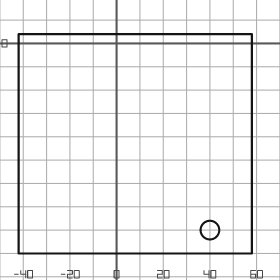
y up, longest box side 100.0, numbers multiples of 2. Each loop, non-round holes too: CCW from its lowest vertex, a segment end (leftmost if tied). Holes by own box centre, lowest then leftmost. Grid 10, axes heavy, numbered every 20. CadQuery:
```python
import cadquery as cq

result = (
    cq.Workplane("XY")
    .moveTo(-42.0, -90.0)
    .lineTo(58.0, -90.0)
    .lineTo(58.0, 4.0)
    .lineTo(-42.0, 4.0)
    .close()
    .moveTo(40.0, -80.0)
    .circle(4.0)
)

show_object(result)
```